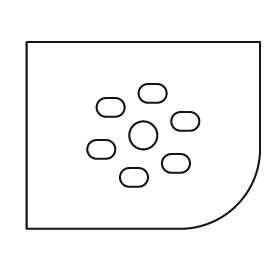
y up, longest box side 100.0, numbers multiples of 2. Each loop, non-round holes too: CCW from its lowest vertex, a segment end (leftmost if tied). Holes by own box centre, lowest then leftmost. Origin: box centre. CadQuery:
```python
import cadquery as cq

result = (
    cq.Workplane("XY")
    .moveTo(-50.0, -40.0)
    .lineTo(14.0, -40.0)
    .threePointArc((40.0, -30.0), (50.0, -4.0))
    .lineTo(50.0, 40.0)
    .lineTo(-50.0, 40.0)
    .close()
    .moveTo(-6.0, -22.0)
    .lineTo(-2.0, -22.0)
    .threePointArc((2.0, -18.0), (-2.0, -14.0))
    .lineTo(-6.0, -14.0)
    .threePointArc((-10.0, -18.0), (-6.0, -22.0))
    .close()
    .moveTo(12.0, -16.0)
    .lineTo(16.0, -16.0)
    .threePointArc((20.0, -12.0), (16.0, -8.0))
    .lineTo(12.0, -8.0)
    .threePointArc((8.0, -12.0), (12.0, -16.0))
    .close()
    .moveTo(-20.0, -10.0)
    .lineTo(-16.0, -10.0)
    .threePointArc((-12.0, -6.0), (-16.0, -2.0))
    .lineTo(-20.0, -2.0)
    .threePointArc((-24.0, -6.0), (-20.0, -10.0))
    .close()
    .moveTo(0.0, 0.0)
    .circle(6.0)
    .moveTo(16.0, 2.0)
    .lineTo(20.0, 2.0)
    .threePointArc((24.0, 6.0), (20.0, 10.0))
    .lineTo(16.0, 10.0)
    .threePointArc((12.0, 6.0), (16.0, 2.0))
    .close()
    .moveTo(-16.0, 8.0)
    .lineTo(-12.0, 8.0)
    .threePointArc((-8.0, 12.0), (-12.0, 16.0))
    .lineTo(-16.0, 16.0)
    .threePointArc((-20.0, 12.0), (-16.0, 8.0))
    .close()
    .moveTo(2.0, 14.0)
    .lineTo(6.0, 14.0)
    .threePointArc((10.0, 18.0), (6.0, 22.0))
    .lineTo(2.0, 22.0)
    .threePointArc((-2.0, 18.0), (2.0, 14.0))
    .close()
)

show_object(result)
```